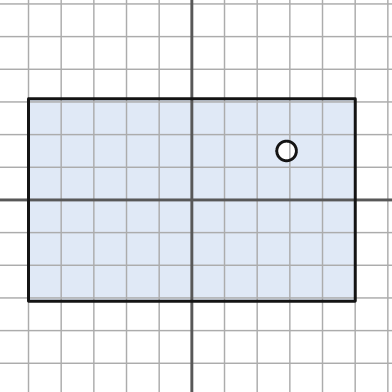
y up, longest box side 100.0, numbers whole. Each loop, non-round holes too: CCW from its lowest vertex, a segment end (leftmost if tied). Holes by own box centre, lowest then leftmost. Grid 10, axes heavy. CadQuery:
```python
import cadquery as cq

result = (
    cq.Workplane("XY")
    .moveTo(-50.0, -31.0)
    .lineTo(50.0, -31.0)
    .lineTo(50.0, 31.0)
    .lineTo(-50.0, 31.0)
    .close()
    .moveTo(29.0, 15.0)
    .circle(3.0)
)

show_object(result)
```